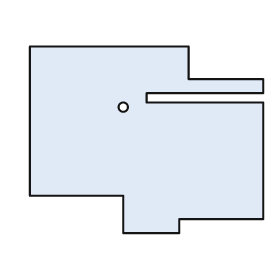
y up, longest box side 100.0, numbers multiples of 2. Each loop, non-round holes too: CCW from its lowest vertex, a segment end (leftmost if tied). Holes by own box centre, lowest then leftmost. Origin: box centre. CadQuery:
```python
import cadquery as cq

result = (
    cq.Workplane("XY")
    .moveTo(-10.0, -40.0)
    .lineTo(14.0, -40.0)
    .lineTo(14.0, -34.0)
    .lineTo(50.0, -34.0)
    .lineTo(50.0, 16.0)
    .lineTo(0.0, 16.0)
    .lineTo(0.0, 20.0)
    .lineTo(50.0, 20.0)
    .lineTo(50.0, 26.0)
    .lineTo(18.0, 26.0)
    .lineTo(18.0, 40.0)
    .lineTo(-50.0, 40.0)
    .lineTo(-50.0, -24.0)
    .lineTo(-10.0, -24.0)
    .close()
    .moveTo(-10.0, 14.0)
    .circle(2.0)
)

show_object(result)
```